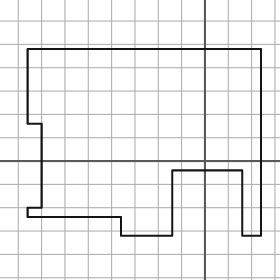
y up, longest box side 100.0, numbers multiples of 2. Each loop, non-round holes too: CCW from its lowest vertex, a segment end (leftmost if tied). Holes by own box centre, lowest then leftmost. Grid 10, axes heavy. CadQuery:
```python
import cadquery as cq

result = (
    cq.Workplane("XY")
    .moveTo(-36.0, -32.0)
    .lineTo(-14.0, -32.0)
    .lineTo(-14.0, -4.0)
    .lineTo(16.0, -4.0)
    .lineTo(16.0, -32.0)
    .lineTo(24.0, -32.0)
    .lineTo(24.0, 48.0)
    .lineTo(-76.0, 48.0)
    .lineTo(-76.0, 16.0)
    .lineTo(-70.0, 16.0)
    .lineTo(-70.0, -20.0)
    .lineTo(-76.0, -20.0)
    .lineTo(-76.0, -24.0)
    .lineTo(-36.0, -24.0)
    .close()
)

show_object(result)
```